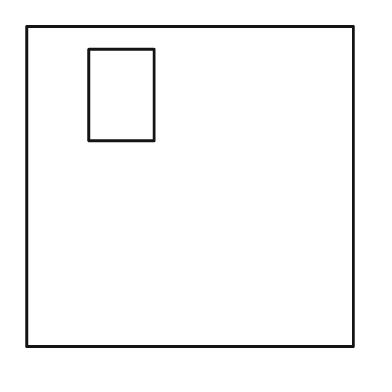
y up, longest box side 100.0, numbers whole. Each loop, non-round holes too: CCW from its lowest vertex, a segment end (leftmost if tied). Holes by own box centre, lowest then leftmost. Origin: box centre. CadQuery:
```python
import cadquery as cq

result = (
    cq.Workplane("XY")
    .moveTo(-50.0, -49.0)
    .lineTo(50.0, -49.0)
    .lineTo(50.0, 49.0)
    .lineTo(-50.0, 49.0)
    .close()
    .moveTo(-31.0, 14.0)
    .lineTo(-11.0, 14.0)
    .lineTo(-11.0, 42.0)
    .lineTo(-31.0, 42.0)
    .close()
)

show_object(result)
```